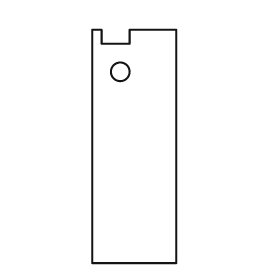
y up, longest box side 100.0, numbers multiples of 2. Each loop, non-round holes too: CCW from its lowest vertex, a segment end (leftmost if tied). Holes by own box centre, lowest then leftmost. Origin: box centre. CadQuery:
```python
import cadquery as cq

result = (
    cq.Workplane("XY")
    .moveTo(-18.0, -50.0)
    .lineTo(18.0, -50.0)
    .lineTo(18.0, 50.0)
    .lineTo(-2.0, 50.0)
    .lineTo(-2.0, 44.0)
    .lineTo(-14.0, 44.0)
    .lineTo(-14.0, 50.0)
    .lineTo(-18.0, 50.0)
    .close()
    .moveTo(-6.0, 32.0)
    .circle(4.0)
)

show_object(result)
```